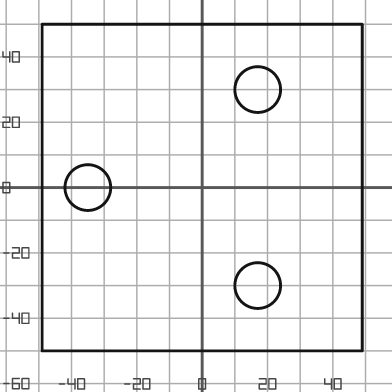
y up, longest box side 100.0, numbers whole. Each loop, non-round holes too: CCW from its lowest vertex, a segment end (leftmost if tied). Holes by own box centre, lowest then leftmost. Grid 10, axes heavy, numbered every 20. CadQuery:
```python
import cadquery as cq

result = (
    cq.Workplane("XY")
    .moveTo(-49.0, -50.0)
    .lineTo(49.0, -50.0)
    .lineTo(49.0, 50.0)
    .lineTo(-49.0, 50.0)
    .close()
    .moveTo(17.0, -30.0)
    .circle(7.0)
    .moveTo(-35.0, 0.0)
    .circle(7.0)
    .moveTo(17.0, 30.0)
    .circle(7.0)
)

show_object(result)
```